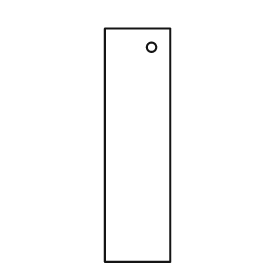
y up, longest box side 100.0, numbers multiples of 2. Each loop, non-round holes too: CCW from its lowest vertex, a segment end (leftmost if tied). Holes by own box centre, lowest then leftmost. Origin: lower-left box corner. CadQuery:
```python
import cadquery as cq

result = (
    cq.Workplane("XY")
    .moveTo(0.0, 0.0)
    .lineTo(28.0, 0.0)
    .lineTo(28.0, 100.0)
    .lineTo(0.0, 100.0)
    .close()
    .moveTo(20.0, 92.0)
    .circle(2.0)
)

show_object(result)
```